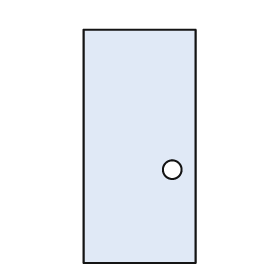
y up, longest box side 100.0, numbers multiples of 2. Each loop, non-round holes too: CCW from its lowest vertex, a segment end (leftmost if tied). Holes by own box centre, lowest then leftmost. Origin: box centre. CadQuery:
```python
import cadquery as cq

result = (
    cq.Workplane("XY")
    .moveTo(-24.0, -50.0)
    .lineTo(24.0, -50.0)
    .lineTo(24.0, 50.0)
    .lineTo(-24.0, 50.0)
    .close()
    .moveTo(14.0, -10.0)
    .circle(4.0)
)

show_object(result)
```